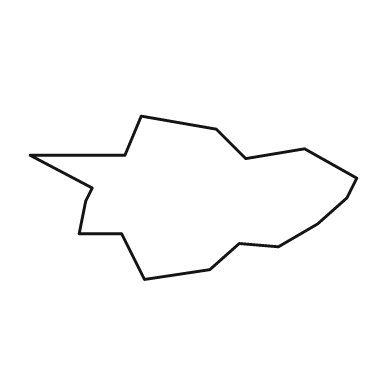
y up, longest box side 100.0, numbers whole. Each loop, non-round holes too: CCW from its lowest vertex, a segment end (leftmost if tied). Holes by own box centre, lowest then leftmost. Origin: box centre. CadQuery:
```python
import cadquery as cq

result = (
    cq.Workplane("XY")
    .moveTo(-15.0, -25.0)
    .lineTo(5.0, -22.0)
    .lineTo(14.0, -14.0)
    .lineTo(26.0, -15.0)
    .lineTo(38.0, -8.0)
    .lineTo(47.0, 0.0)
    .lineTo(50.0, 6.0)
    .lineTo(34.0, 15.0)
    .lineTo(16.0, 12.0)
    .lineTo(7.0, 21.0)
    .lineTo(-16.0, 25.0)
    .lineTo(-21.0, 13.0)
    .lineTo(-50.0, 13.0)
    .lineTo(-31.0, 3.0)
    .lineTo(-33.0, -1.0)
    .lineTo(-35.0, -11.0)
    .lineTo(-22.0, -11.0)
    .close()
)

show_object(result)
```